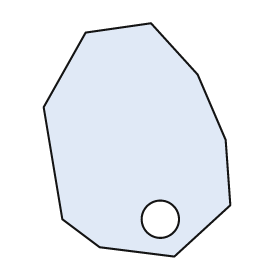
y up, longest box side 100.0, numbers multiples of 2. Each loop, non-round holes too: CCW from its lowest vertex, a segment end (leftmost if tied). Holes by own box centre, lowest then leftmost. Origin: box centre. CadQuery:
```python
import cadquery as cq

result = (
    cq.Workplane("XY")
    .moveTo(16.0, -50.0)
    .lineTo(40.0, -28.0)
    .lineTo(38.0, 0.0)
    .lineTo(26.0, 28.0)
    .lineTo(6.0, 50.0)
    .lineTo(-22.0, 46.0)
    .lineTo(-40.0, 14.0)
    .lineTo(-32.0, -34.0)
    .lineTo(-16.0, -46.0)
    .close()
    .moveTo(10.0, -34.0)
    .circle(8.0)
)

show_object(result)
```